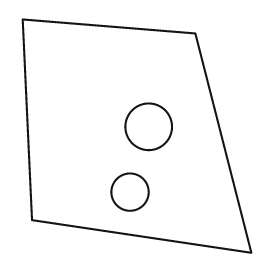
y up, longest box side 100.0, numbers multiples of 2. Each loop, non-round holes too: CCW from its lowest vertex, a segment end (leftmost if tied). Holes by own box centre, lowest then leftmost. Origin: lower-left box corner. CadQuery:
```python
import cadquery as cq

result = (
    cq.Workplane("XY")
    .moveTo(98.0, 0.0)
    .lineTo(74.0, 94.0)
    .lineTo(0.0, 100.0)
    .lineTo(4.0, 14.0)
    .close()
    .moveTo(46.0, 26.0)
    .circle(8.0)
    .moveTo(54.0, 54.0)
    .circle(10.0)
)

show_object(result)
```